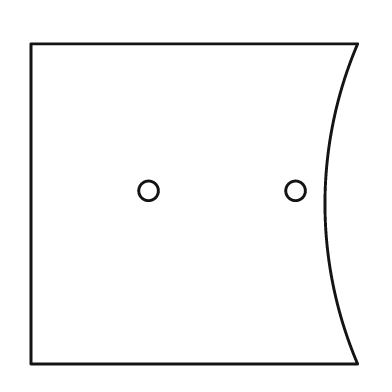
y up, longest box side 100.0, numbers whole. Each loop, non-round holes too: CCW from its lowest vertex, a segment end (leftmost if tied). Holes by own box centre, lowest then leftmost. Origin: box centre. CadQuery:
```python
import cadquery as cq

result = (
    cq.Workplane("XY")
    .moveTo(-50.0, -49.0)
    .lineTo(50.0, -49.0)
    .threePointArc((40.0, 0.0), (50.0, 49.0))
    .lineTo(-50.0, 49.0)
    .close()
    .moveTo(-14.0, 4.0)
    .circle(3.0)
    .moveTo(31.0, 4.0)
    .circle(3.0)
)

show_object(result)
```